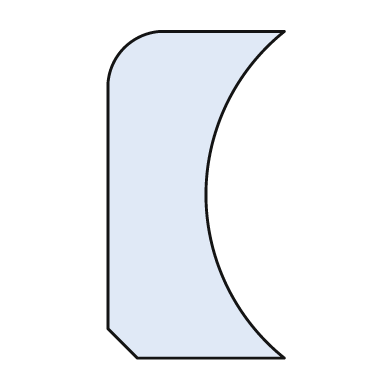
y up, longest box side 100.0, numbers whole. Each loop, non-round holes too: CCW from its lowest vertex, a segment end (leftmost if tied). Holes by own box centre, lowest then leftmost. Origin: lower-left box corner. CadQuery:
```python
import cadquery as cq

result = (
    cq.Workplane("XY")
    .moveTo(9.0, 0.0)
    .lineTo(54.0, 0.0)
    .threePointArc((30.0, 50.0), (54.0, 100.0))
    .lineTo(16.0, 100.0)
    .threePointArc((5.0, 95.0), (0.0, 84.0))
    .lineTo(0.0, 9.0)
    .close()
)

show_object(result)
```